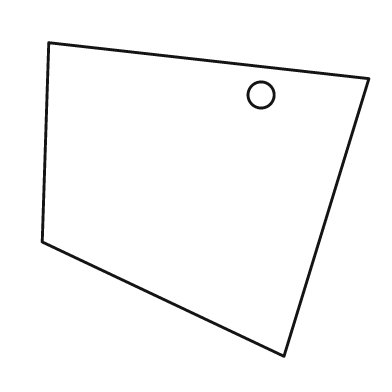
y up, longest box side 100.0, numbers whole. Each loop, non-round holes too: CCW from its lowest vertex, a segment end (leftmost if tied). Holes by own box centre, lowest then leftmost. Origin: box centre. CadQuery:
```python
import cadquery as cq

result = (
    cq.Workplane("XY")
    .moveTo(24.0, -48.0)
    .lineTo(50.0, 37.0)
    .lineTo(-48.0, 48.0)
    .lineTo(-50.0, -13.0)
    .close()
    .moveTo(17.0, 32.0)
    .circle(4.0)
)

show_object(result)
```